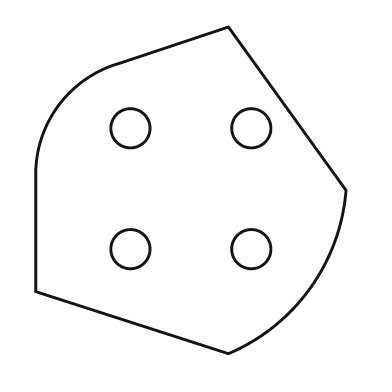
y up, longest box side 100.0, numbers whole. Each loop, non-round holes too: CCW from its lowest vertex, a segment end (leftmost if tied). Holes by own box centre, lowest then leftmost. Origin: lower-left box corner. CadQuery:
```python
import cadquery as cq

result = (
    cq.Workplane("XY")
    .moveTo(59.0, 0.0)
    .threePointArc((84.0, 20.0), (95.0, 50.0))
    .lineTo(59.0, 100.0)
    .lineTo(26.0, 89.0)
    .threePointArc((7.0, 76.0), (0.0, 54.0))
    .lineTo(0.0, 19.0)
    .close()
    .moveTo(29.0, 32.0)
    .circle(6.0)
    .moveTo(66.0, 32.0)
    .circle(6.0)
    .moveTo(29.0, 69.0)
    .circle(6.0)
    .moveTo(66.0, 69.0)
    .circle(6.0)
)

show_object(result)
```